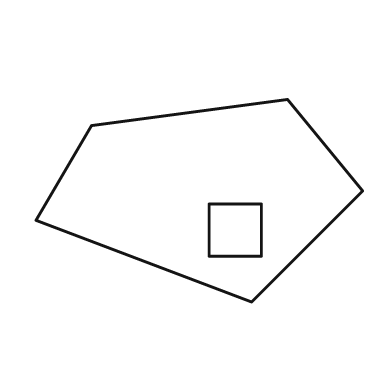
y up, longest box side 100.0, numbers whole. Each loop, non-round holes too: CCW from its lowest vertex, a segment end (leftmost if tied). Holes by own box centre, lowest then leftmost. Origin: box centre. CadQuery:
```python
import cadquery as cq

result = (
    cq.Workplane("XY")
    .moveTo(16.0, -31.0)
    .lineTo(50.0, 3.0)
    .lineTo(27.0, 31.0)
    .lineTo(-33.0, 23.0)
    .lineTo(-50.0, -6.0)
    .close()
    .moveTo(3.0, -17.0)
    .lineTo(19.0, -17.0)
    .lineTo(19.0, -1.0)
    .lineTo(3.0, -1.0)
    .close()
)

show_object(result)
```